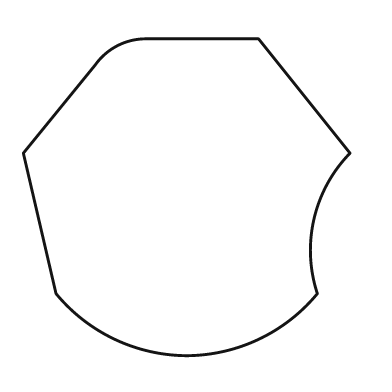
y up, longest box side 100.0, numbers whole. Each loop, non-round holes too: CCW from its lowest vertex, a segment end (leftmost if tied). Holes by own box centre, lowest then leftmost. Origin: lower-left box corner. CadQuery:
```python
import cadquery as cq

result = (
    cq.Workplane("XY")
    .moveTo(50.0, 0.0)
    .threePointArc((72.0, 5.0), (90.0, 19.0))
    .threePointArc((89.0, 42.0), (100.0, 62.0))
    .lineTo(72.0, 97.0)
    .lineTo(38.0, 97.0)
    .threePointArc((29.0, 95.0), (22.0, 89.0))
    .lineTo(0.0, 62.0)
    .lineTo(10.0, 19.0)
    .threePointArc((28.0, 5.0), (50.0, 0.0))
    .close()
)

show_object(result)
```